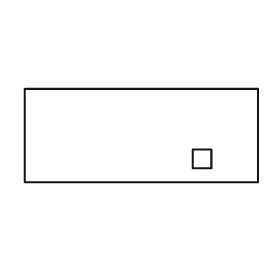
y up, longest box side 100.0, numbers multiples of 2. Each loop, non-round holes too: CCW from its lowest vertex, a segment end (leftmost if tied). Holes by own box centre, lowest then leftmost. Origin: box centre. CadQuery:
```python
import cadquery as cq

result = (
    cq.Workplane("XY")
    .moveTo(-50.0, -20.0)
    .lineTo(50.0, -20.0)
    .lineTo(50.0, 20.0)
    .lineTo(-50.0, 20.0)
    .close()
    .moveTo(22.0, -14.0)
    .lineTo(30.0, -14.0)
    .lineTo(30.0, -6.0)
    .lineTo(22.0, -6.0)
    .close()
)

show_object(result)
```